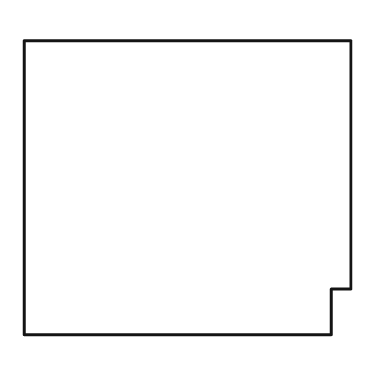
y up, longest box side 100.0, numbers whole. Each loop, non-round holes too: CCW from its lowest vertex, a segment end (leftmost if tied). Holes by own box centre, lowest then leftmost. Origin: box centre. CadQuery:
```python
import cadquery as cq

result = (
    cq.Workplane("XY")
    .moveTo(-50.0, -45.0)
    .lineTo(44.0, -45.0)
    .lineTo(44.0, -31.0)
    .lineTo(50.0, -31.0)
    .lineTo(50.0, 45.0)
    .lineTo(-50.0, 45.0)
    .close()
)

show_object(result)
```